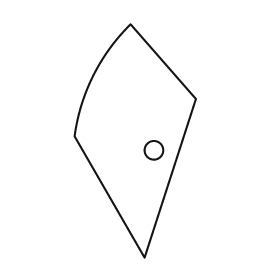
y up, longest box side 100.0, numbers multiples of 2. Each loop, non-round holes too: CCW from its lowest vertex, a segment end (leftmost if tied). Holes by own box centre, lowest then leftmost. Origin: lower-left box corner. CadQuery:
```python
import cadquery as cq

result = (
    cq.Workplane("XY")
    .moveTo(30.0, 0.0)
    .lineTo(52.0, 68.0)
    .lineTo(24.0, 100.0)
    .threePointArc((8.0, 78.0), (0.0, 52.0))
    .close()
    .moveTo(34.0, 46.0)
    .circle(4.0)
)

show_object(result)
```